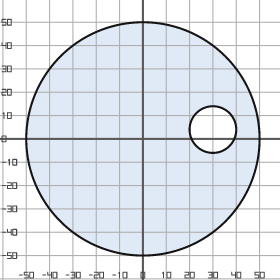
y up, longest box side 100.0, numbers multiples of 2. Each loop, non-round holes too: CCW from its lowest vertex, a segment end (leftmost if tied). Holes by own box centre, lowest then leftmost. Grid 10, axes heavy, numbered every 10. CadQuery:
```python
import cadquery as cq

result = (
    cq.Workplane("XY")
    .moveTo(0.0, 0.0)
    .circle(50.0)
    .moveTo(30.0, 4.0)
    .circle(10.0)
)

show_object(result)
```